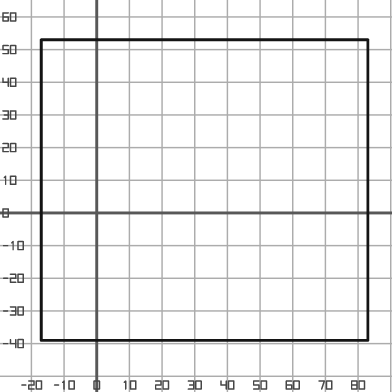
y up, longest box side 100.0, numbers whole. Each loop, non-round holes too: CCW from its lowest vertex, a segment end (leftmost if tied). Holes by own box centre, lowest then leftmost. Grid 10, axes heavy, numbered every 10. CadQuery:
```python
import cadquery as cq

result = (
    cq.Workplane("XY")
    .moveTo(-17.0, -39.0)
    .lineTo(83.0, -39.0)
    .lineTo(83.0, 53.0)
    .lineTo(-17.0, 53.0)
    .close()
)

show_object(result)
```